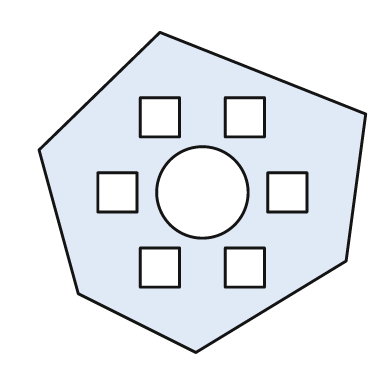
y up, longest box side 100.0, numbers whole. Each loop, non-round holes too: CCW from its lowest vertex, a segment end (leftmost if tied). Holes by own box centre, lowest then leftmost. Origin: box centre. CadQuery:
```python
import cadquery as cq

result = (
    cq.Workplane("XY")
    .moveTo(-2.0, -49.0)
    .lineTo(44.0, -21.0)
    .lineTo(50.0, 24.0)
    .lineTo(-13.0, 49.0)
    .lineTo(-50.0, 13.0)
    .lineTo(-38.0, -31.0)
    .close()
    .moveTo(-19.0, -29.0)
    .lineTo(-7.0, -29.0)
    .lineTo(-7.0, -17.0)
    .lineTo(-19.0, -17.0)
    .close()
    .moveTo(7.0, -29.0)
    .lineTo(19.0, -29.0)
    .lineTo(19.0, -17.0)
    .lineTo(7.0, -17.0)
    .close()
    .moveTo(-32.0, -6.0)
    .lineTo(-20.0, -6.0)
    .lineTo(-20.0, 6.0)
    .lineTo(-32.0, 6.0)
    .close()
    .moveTo(0.0, 0.0)
    .circle(14.0)
    .moveTo(20.0, -6.0)
    .lineTo(32.0, -6.0)
    .lineTo(32.0, 6.0)
    .lineTo(20.0, 6.0)
    .close()
    .moveTo(-19.0, 17.0)
    .lineTo(-7.0, 17.0)
    .lineTo(-7.0, 29.0)
    .lineTo(-19.0, 29.0)
    .close()
    .moveTo(7.0, 17.0)
    .lineTo(19.0, 17.0)
    .lineTo(19.0, 29.0)
    .lineTo(7.0, 29.0)
    .close()
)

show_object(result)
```